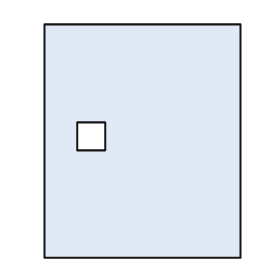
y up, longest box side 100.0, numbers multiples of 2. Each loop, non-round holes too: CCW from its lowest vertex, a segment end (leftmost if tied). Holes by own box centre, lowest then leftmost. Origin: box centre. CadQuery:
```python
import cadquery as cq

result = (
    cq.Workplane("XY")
    .moveTo(-42.0, -50.0)
    .lineTo(42.0, -50.0)
    .lineTo(42.0, 50.0)
    .lineTo(-42.0, 50.0)
    .close()
    .moveTo(-28.0, -4.0)
    .lineTo(-16.0, -4.0)
    .lineTo(-16.0, 8.0)
    .lineTo(-28.0, 8.0)
    .close()
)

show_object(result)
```